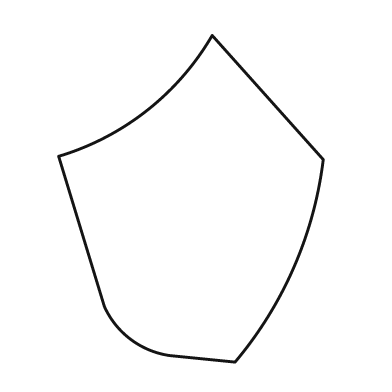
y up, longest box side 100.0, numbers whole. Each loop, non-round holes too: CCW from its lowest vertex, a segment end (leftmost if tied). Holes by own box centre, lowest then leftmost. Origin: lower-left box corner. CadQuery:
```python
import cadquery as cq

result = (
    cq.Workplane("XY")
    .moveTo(54.0, 0.0)
    .threePointArc((72.0, 29.0), (81.0, 62.0))
    .lineTo(47.0, 100.0)
    .threePointArc((27.0, 77.0), (0.0, 63.0))
    .lineTo(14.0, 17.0)
    .threePointArc((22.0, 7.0), (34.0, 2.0))
    .close()
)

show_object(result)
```